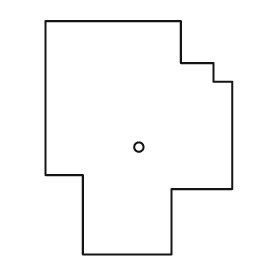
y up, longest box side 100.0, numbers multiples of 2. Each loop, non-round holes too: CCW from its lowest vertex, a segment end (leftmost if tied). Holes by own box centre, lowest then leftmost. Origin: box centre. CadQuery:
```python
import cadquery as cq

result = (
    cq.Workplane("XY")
    .moveTo(-24.0, -50.0)
    .lineTo(14.0, -50.0)
    .lineTo(14.0, -22.0)
    .lineTo(40.0, -22.0)
    .lineTo(40.0, 24.0)
    .lineTo(32.0, 24.0)
    .lineTo(32.0, 32.0)
    .lineTo(18.0, 32.0)
    .lineTo(18.0, 50.0)
    .lineTo(-40.0, 50.0)
    .lineTo(-40.0, -16.0)
    .lineTo(-24.0, -16.0)
    .close()
    .moveTo(0.0, -4.0)
    .circle(2.0)
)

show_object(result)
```